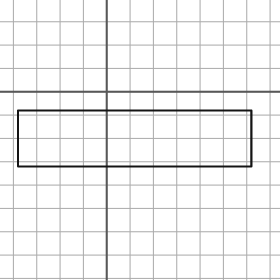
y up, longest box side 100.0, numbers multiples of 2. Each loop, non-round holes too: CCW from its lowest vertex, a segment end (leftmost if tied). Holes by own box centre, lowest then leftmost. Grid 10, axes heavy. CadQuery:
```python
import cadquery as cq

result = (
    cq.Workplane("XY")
    .moveTo(-38.0, -32.0)
    .lineTo(62.0, -32.0)
    .lineTo(62.0, -8.0)
    .lineTo(-38.0, -8.0)
    .close()
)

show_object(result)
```